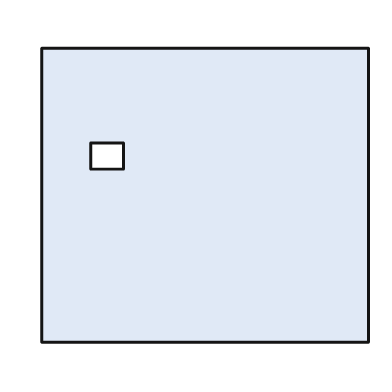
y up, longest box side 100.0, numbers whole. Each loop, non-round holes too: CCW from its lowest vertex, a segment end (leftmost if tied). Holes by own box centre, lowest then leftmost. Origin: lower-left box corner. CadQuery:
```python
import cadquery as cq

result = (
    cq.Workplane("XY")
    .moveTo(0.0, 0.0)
    .lineTo(100.0, 0.0)
    .lineTo(100.0, 90.0)
    .lineTo(0.0, 90.0)
    .close()
    .moveTo(15.0, 53.0)
    .lineTo(25.0, 53.0)
    .lineTo(25.0, 61.0)
    .lineTo(15.0, 61.0)
    .close()
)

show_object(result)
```